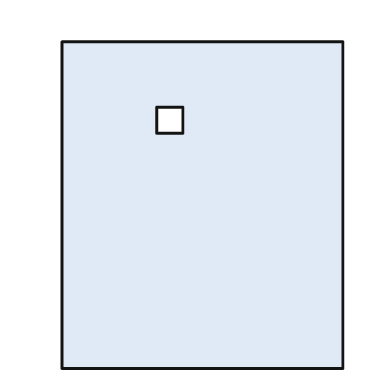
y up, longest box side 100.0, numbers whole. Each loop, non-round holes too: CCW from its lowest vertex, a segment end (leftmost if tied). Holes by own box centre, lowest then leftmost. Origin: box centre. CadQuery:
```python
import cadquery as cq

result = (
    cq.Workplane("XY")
    .moveTo(-43.0, -50.0)
    .lineTo(43.0, -50.0)
    .lineTo(43.0, 50.0)
    .lineTo(-43.0, 50.0)
    .close()
    .moveTo(-14.0, 22.0)
    .lineTo(-6.0, 22.0)
    .lineTo(-6.0, 30.0)
    .lineTo(-14.0, 30.0)
    .close()
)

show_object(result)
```